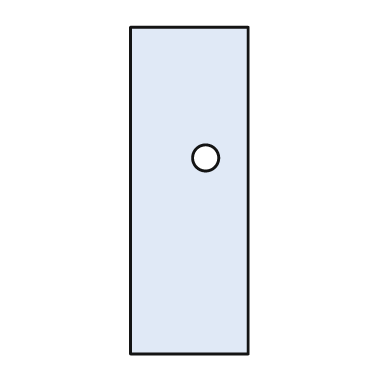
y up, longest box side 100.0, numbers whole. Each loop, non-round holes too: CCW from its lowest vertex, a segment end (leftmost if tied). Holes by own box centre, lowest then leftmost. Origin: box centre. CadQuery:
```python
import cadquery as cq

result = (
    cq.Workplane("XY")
    .moveTo(-18.0, -50.0)
    .lineTo(18.0, -50.0)
    .lineTo(18.0, 50.0)
    .lineTo(-18.0, 50.0)
    .close()
    .moveTo(5.0, 10.0)
    .circle(4.0)
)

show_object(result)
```